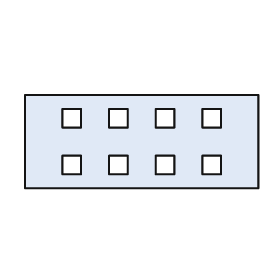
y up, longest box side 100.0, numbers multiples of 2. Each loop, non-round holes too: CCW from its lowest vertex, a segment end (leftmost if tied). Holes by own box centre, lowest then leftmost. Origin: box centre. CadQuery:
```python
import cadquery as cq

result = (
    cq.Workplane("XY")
    .moveTo(-50.0, -20.0)
    .lineTo(50.0, -20.0)
    .lineTo(50.0, 20.0)
    .lineTo(-50.0, 20.0)
    .close()
    .moveTo(-34.0, -14.0)
    .lineTo(-26.0, -14.0)
    .lineTo(-26.0, -6.0)
    .lineTo(-34.0, -6.0)
    .close()
    .moveTo(-14.0, -14.0)
    .lineTo(-6.0, -14.0)
    .lineTo(-6.0, -6.0)
    .lineTo(-14.0, -6.0)
    .close()
    .moveTo(6.0, -14.0)
    .lineTo(14.0, -14.0)
    .lineTo(14.0, -6.0)
    .lineTo(6.0, -6.0)
    .close()
    .moveTo(26.0, -14.0)
    .lineTo(34.0, -14.0)
    .lineTo(34.0, -6.0)
    .lineTo(26.0, -6.0)
    .close()
    .moveTo(-34.0, 6.0)
    .lineTo(-26.0, 6.0)
    .lineTo(-26.0, 14.0)
    .lineTo(-34.0, 14.0)
    .close()
    .moveTo(-14.0, 6.0)
    .lineTo(-6.0, 6.0)
    .lineTo(-6.0, 14.0)
    .lineTo(-14.0, 14.0)
    .close()
    .moveTo(6.0, 6.0)
    .lineTo(14.0, 6.0)
    .lineTo(14.0, 14.0)
    .lineTo(6.0, 14.0)
    .close()
    .moveTo(26.0, 6.0)
    .lineTo(34.0, 6.0)
    .lineTo(34.0, 14.0)
    .lineTo(26.0, 14.0)
    .close()
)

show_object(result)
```